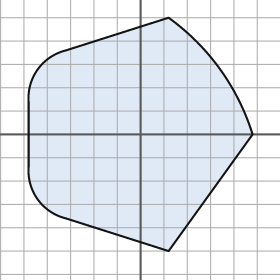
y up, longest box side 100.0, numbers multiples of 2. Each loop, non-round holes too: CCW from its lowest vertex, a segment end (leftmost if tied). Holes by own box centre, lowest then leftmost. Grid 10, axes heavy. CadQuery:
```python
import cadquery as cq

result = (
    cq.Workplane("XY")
    .moveTo(12.0, -50.0)
    .lineTo(48.0, 0.0)
    .threePointArc((34.0, 28.0), (12.0, 50.0))
    .lineTo(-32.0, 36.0)
    .threePointArc((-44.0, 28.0), (-48.0, 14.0))
    .lineTo(-48.0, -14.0)
    .threePointArc((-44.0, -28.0), (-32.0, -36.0))
    .close()
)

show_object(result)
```